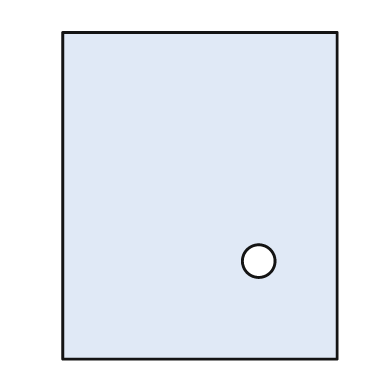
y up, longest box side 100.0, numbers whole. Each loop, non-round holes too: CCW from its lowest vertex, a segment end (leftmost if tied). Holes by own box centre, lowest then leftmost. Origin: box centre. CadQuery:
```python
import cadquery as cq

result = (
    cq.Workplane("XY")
    .moveTo(-42.0, -50.0)
    .lineTo(42.0, -50.0)
    .lineTo(42.0, 50.0)
    .lineTo(-42.0, 50.0)
    .close()
    .moveTo(18.0, -20.0)
    .circle(5.0)
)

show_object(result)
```